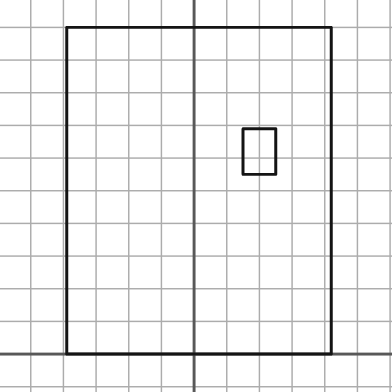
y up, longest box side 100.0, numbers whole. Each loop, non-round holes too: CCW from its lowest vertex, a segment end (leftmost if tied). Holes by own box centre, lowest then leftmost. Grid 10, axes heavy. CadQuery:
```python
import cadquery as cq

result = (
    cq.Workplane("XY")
    .moveTo(-39.0, 0.0)
    .lineTo(42.0, 0.0)
    .lineTo(42.0, 100.0)
    .lineTo(-39.0, 100.0)
    .close()
    .moveTo(15.0, 55.0)
    .lineTo(25.0, 55.0)
    .lineTo(25.0, 69.0)
    .lineTo(15.0, 69.0)
    .close()
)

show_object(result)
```